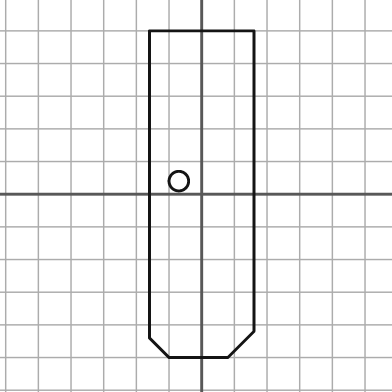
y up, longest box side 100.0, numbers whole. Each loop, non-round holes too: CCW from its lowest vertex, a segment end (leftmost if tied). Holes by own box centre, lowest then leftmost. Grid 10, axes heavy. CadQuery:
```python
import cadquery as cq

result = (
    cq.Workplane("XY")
    .moveTo(-10.0, -50.0)
    .lineTo(8.0, -50.0)
    .lineTo(16.0, -42.0)
    .lineTo(16.0, 50.0)
    .lineTo(-16.0, 50.0)
    .lineTo(-16.0, -44.0)
    .close()
    .moveTo(-7.0, 4.0)
    .circle(3.0)
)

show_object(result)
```